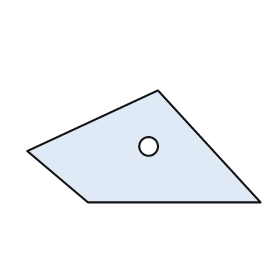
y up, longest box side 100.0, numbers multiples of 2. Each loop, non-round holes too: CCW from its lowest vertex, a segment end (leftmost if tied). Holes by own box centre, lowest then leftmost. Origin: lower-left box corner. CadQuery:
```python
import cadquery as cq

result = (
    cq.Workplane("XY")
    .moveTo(26.0, 0.0)
    .lineTo(100.0, 0.0)
    .lineTo(56.0, 48.0)
    .lineTo(0.0, 22.0)
    .close()
    .moveTo(52.0, 24.0)
    .circle(4.0)
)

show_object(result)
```